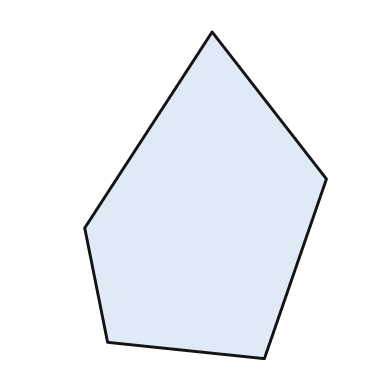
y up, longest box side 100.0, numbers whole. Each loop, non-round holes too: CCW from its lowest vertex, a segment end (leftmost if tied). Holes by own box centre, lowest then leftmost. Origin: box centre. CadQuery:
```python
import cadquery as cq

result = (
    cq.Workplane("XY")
    .moveTo(18.0, -50.0)
    .lineTo(37.0, 5.0)
    .lineTo(2.0, 50.0)
    .lineTo(-37.0, -10.0)
    .lineTo(-30.0, -45.0)
    .close()
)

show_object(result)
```